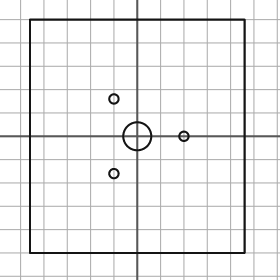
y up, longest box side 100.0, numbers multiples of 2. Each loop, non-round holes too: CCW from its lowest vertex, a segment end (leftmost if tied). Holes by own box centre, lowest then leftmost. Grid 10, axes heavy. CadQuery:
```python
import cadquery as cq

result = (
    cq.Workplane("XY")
    .moveTo(-46.0, -50.0)
    .lineTo(46.0, -50.0)
    .lineTo(46.0, 50.0)
    .lineTo(-46.0, 50.0)
    .close()
    .moveTo(-10.0, -16.0)
    .circle(2.0)
    .moveTo(0.0, 0.0)
    .circle(6.0)
    .moveTo(20.0, 0.0)
    .circle(2.0)
    .moveTo(-10.0, 16.0)
    .circle(2.0)
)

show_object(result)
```